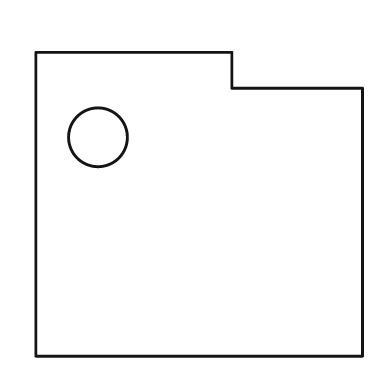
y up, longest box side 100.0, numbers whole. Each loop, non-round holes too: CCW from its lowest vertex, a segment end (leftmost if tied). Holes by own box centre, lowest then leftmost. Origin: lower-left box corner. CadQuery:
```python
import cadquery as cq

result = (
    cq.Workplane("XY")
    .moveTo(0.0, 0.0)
    .lineTo(100.0, 0.0)
    .lineTo(100.0, 82.0)
    .lineTo(60.0, 82.0)
    .lineTo(60.0, 93.0)
    .lineTo(0.0, 93.0)
    .close()
    .moveTo(19.0, 67.0)
    .circle(9.0)
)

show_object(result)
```